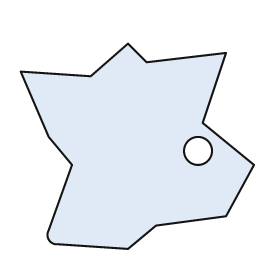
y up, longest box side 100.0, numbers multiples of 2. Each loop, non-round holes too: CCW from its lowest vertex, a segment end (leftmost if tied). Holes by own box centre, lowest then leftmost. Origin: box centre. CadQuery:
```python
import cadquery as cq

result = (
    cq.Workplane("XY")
    .moveTo(-4.0, -44.0)
    .lineTo(8.0, -34.0)
    .lineTo(38.0, -30.0)
    .lineTo(50.0, -8.0)
    .lineTo(28.0, 10.0)
    .lineTo(38.0, 40.0)
    .lineTo(4.0, 36.0)
    .lineTo(-4.0, 44.0)
    .lineTo(-20.0, 30.0)
    .lineTo(-50.0, 32.0)
    .lineTo(-38.0, 4.0)
    .lineTo(-28.0, -8.0)
    .lineTo(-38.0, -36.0)
    .threePointArc((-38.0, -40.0), (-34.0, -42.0))
    .close()
    .moveTo(26.0, -2.0)
    .circle(6.0)
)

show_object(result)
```